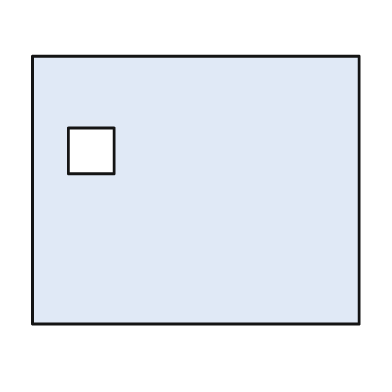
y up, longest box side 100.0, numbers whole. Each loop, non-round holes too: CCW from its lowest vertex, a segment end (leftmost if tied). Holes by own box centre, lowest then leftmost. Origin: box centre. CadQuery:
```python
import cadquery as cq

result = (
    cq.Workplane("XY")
    .moveTo(-50.0, -41.0)
    .lineTo(50.0, -41.0)
    .lineTo(50.0, 41.0)
    .lineTo(-50.0, 41.0)
    .close()
    .moveTo(-39.0, 5.0)
    .lineTo(-25.0, 5.0)
    .lineTo(-25.0, 19.0)
    .lineTo(-39.0, 19.0)
    .close()
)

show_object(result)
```